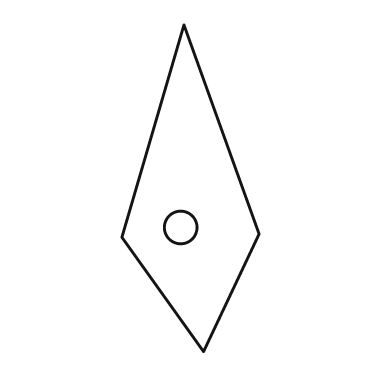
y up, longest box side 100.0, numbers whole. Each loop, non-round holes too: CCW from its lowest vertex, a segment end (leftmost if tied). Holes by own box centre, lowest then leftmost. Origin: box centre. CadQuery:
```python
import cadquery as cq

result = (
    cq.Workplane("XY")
    .moveTo(4.0, -50.0)
    .lineTo(21.0, -14.0)
    .lineTo(-2.0, 50.0)
    .lineTo(-21.0, -15.0)
    .close()
    .moveTo(-3.0, -12.0)
    .circle(5.0)
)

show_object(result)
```